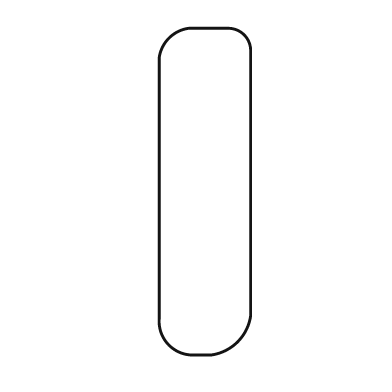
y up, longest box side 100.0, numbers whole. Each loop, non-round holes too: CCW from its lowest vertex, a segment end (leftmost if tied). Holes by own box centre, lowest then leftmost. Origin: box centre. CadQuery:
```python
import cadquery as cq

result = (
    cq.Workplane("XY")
    .moveTo(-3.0, -50.0)
    .lineTo(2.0, -50.0)
    .threePointArc((10.0, -46.0), (14.0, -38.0))
    .lineTo(14.0, 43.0)
    .threePointArc((12.0, 48.0), (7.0, 50.0))
    .lineTo(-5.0, 50.0)
    .threePointArc((-11.0, 47.0), (-14.0, 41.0))
    .lineTo(-14.0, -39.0)
    .threePointArc((-11.0, -47.0), (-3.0, -50.0))
    .close()
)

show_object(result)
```